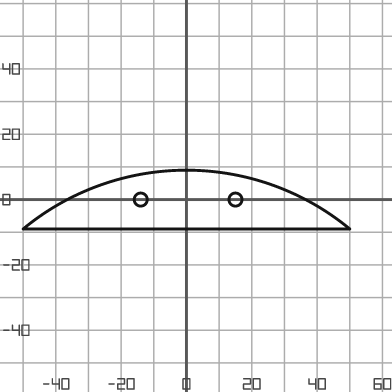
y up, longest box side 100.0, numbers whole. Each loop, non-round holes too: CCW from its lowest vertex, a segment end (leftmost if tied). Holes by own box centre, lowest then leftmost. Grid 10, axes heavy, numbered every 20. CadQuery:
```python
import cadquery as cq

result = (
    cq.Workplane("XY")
    .moveTo(-50.0, -9.0)
    .lineTo(50.0, -9.0)
    .threePointArc((0.0, 9.0), (-50.0, -9.0))
    .close()
    .moveTo(-14.0, 0.0)
    .circle(2.0)
    .moveTo(15.0, 0.0)
    .circle(2.0)
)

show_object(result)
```